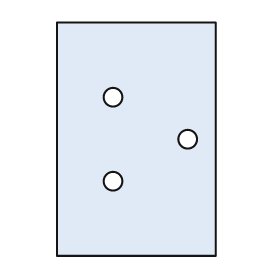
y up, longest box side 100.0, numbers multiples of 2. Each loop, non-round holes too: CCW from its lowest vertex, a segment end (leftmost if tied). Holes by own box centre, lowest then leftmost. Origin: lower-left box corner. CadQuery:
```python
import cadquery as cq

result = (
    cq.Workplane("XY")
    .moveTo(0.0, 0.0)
    .lineTo(68.0, 0.0)
    .lineTo(68.0, 100.0)
    .lineTo(0.0, 100.0)
    .close()
    .moveTo(24.0, 32.0)
    .circle(4.0)
    .moveTo(56.0, 50.0)
    .circle(4.0)
    .moveTo(24.0, 68.0)
    .circle(4.0)
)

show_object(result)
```